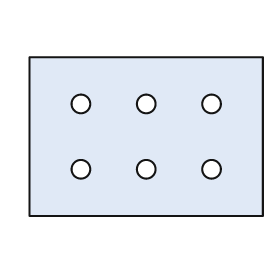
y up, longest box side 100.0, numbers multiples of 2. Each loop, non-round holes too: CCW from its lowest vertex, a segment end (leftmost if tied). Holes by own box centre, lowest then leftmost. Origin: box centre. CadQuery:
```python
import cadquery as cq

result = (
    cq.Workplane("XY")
    .moveTo(-50.0, -34.0)
    .lineTo(50.0, -34.0)
    .lineTo(50.0, 34.0)
    .lineTo(-50.0, 34.0)
    .close()
    .moveTo(-28.0, -14.0)
    .circle(4.0)
    .moveTo(0.0, -14.0)
    .circle(4.0)
    .moveTo(28.0, -14.0)
    .circle(4.0)
    .moveTo(-28.0, 14.0)
    .circle(4.0)
    .moveTo(0.0, 14.0)
    .circle(4.0)
    .moveTo(28.0, 14.0)
    .circle(4.0)
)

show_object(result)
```